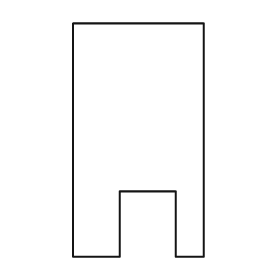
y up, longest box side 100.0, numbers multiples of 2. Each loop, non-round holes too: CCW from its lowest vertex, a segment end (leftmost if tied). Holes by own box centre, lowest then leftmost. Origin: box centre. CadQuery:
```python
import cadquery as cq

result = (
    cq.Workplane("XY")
    .moveTo(-28.0, -50.0)
    .lineTo(-8.0, -50.0)
    .lineTo(-8.0, -22.0)
    .lineTo(16.0, -22.0)
    .lineTo(16.0, -50.0)
    .lineTo(28.0, -50.0)
    .lineTo(28.0, 50.0)
    .lineTo(-28.0, 50.0)
    .close()
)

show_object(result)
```